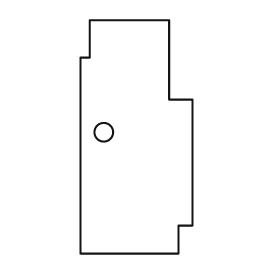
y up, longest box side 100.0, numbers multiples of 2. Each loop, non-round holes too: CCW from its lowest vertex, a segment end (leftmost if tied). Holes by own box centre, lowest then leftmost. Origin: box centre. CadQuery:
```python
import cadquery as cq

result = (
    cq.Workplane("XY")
    .moveTo(-24.0, -50.0)
    .lineTo(18.0, -50.0)
    .lineTo(18.0, -38.0)
    .lineTo(24.0, -38.0)
    .lineTo(24.0, 16.0)
    .lineTo(14.0, 16.0)
    .lineTo(14.0, 50.0)
    .lineTo(-20.0, 50.0)
    .lineTo(-20.0, 34.0)
    .lineTo(-24.0, 34.0)
    .close()
    .moveTo(-14.0, 2.0)
    .circle(4.0)
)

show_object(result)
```